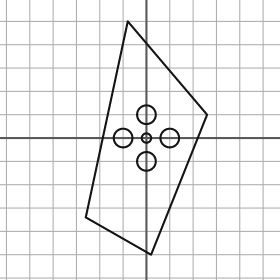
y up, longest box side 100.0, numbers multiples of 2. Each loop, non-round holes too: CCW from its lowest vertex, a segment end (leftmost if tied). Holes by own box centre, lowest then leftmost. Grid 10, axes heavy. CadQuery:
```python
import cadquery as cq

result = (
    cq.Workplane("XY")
    .moveTo(2.0, -50.0)
    .lineTo(26.0, 10.0)
    .lineTo(-8.0, 50.0)
    .lineTo(-26.0, -34.0)
    .close()
    .moveTo(0.0, -10.0)
    .circle(4.0)
    .moveTo(-10.0, 0.0)
    .circle(4.0)
    .moveTo(0.0, 0.0)
    .circle(2.0)
    .moveTo(10.0, 0.0)
    .circle(4.0)
    .moveTo(0.0, 10.0)
    .circle(4.0)
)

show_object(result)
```